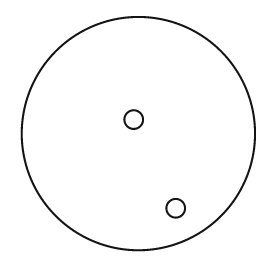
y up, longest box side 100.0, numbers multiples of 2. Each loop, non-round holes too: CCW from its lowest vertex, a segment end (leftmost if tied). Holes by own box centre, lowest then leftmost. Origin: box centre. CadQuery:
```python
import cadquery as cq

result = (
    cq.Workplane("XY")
    .moveTo(0.0, 0.0)
    .circle(50.0)
    .moveTo(16.0, -32.0)
    .circle(4.0)
    .moveTo(-2.0, 6.0)
    .circle(4.0)
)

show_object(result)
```